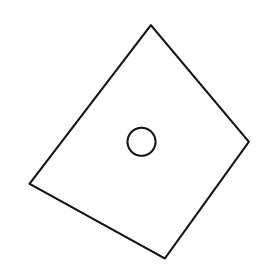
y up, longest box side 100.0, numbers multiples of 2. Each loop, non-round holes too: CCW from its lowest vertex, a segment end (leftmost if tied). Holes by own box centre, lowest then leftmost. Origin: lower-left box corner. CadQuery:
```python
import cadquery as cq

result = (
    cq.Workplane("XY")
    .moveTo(58.0, 0.0)
    .lineTo(94.0, 50.0)
    .lineTo(52.0, 100.0)
    .lineTo(0.0, 32.0)
    .close()
    .moveTo(48.0, 50.0)
    .circle(6.0)
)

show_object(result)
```